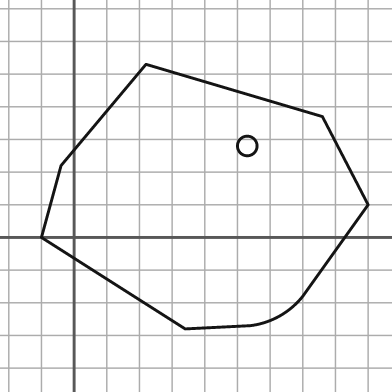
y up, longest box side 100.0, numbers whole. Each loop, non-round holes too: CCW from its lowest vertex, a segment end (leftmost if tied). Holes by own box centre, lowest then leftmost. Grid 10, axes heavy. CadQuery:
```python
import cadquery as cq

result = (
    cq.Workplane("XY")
    .moveTo(34.0, -28.0)
    .lineTo(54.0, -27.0)
    .threePointArc((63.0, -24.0), (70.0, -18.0))
    .lineTo(90.0, 10.0)
    .lineTo(76.0, 37.0)
    .lineTo(22.0, 53.0)
    .lineTo(-4.0, 22.0)
    .lineTo(-10.0, 0.0)
    .close()
    .moveTo(53.0, 28.0)
    .circle(3.0)
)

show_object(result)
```